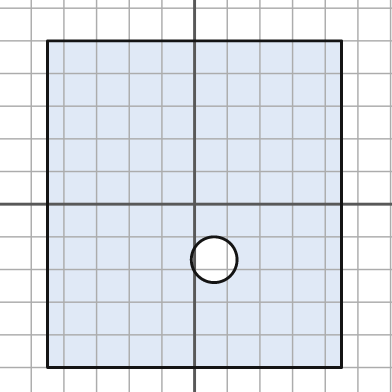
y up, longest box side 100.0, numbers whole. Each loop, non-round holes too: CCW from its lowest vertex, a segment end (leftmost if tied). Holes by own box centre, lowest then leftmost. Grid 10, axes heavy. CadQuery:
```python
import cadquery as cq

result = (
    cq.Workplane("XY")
    .moveTo(-45.0, -50.0)
    .lineTo(45.0, -50.0)
    .lineTo(45.0, 50.0)
    .lineTo(-45.0, 50.0)
    .close()
    .moveTo(6.0, -17.0)
    .circle(7.0)
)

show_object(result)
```